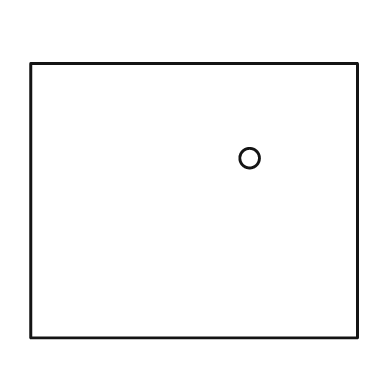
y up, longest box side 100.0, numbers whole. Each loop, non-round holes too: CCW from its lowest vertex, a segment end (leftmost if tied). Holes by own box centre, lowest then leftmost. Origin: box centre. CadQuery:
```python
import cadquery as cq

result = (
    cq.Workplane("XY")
    .moveTo(-50.0, -42.0)
    .lineTo(50.0, -42.0)
    .lineTo(50.0, 42.0)
    .lineTo(-50.0, 42.0)
    .close()
    .moveTo(17.0, 13.0)
    .circle(3.0)
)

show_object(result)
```